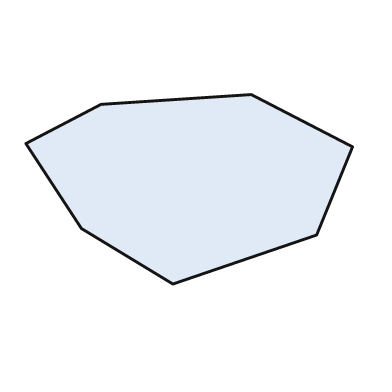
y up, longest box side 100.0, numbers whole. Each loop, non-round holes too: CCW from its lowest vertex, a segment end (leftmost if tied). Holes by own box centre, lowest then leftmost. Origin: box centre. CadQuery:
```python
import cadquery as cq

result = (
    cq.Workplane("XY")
    .moveTo(-5.0, -29.0)
    .lineTo(39.0, -14.0)
    .lineTo(50.0, 13.0)
    .lineTo(19.0, 29.0)
    .lineTo(-27.0, 26.0)
    .lineTo(-50.0, 14.0)
    .lineTo(-33.0, -12.0)
    .close()
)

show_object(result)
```